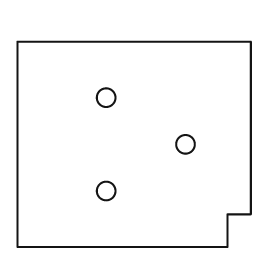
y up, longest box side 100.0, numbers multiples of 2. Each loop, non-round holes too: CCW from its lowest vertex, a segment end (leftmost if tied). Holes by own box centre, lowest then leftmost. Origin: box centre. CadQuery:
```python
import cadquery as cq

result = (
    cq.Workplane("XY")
    .moveTo(-50.0, -44.0)
    .lineTo(40.0, -44.0)
    .lineTo(40.0, -30.0)
    .lineTo(50.0, -30.0)
    .lineTo(50.0, 44.0)
    .lineTo(-50.0, 44.0)
    .close()
    .moveTo(-12.0, -20.0)
    .circle(4.0)
    .moveTo(22.0, 0.0)
    .circle(4.0)
    .moveTo(-12.0, 20.0)
    .circle(4.0)
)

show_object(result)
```